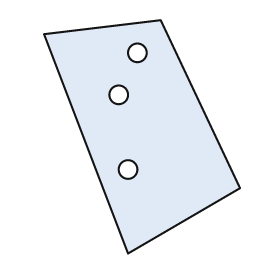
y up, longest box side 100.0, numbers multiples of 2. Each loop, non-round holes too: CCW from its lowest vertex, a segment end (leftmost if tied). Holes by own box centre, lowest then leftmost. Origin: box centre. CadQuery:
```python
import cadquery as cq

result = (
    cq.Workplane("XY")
    .moveTo(-6.0, -50.0)
    .lineTo(42.0, -22.0)
    .lineTo(8.0, 50.0)
    .lineTo(-42.0, 44.0)
    .close()
    .moveTo(-6.0, -14.0)
    .circle(4.0)
    .moveTo(-10.0, 18.0)
    .circle(4.0)
    .moveTo(-2.0, 36.0)
    .circle(4.0)
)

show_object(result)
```